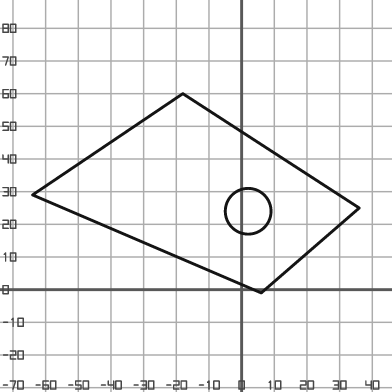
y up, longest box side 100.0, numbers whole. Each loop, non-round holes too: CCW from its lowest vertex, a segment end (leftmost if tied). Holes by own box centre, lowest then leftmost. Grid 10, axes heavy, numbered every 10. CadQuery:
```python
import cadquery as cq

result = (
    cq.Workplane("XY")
    .moveTo(6.0, -1.0)
    .lineTo(36.0, 25.0)
    .lineTo(-18.0, 60.0)
    .lineTo(-64.0, 29.0)
    .close()
    .moveTo(2.0, 24.0)
    .circle(7.0)
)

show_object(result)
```